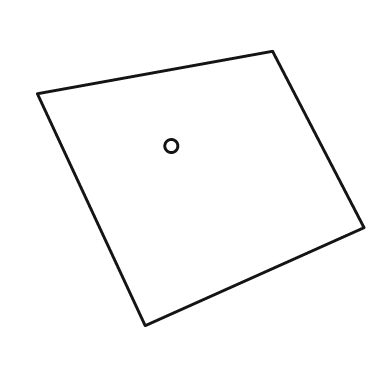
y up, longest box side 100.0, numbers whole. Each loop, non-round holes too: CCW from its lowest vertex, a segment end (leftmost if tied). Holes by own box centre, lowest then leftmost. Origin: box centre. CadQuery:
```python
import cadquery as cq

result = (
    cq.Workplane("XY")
    .moveTo(-17.0, -42.0)
    .lineTo(50.0, -12.0)
    .lineTo(22.0, 42.0)
    .lineTo(-50.0, 29.0)
    .close()
    .moveTo(-9.0, 13.0)
    .circle(2.0)
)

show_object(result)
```